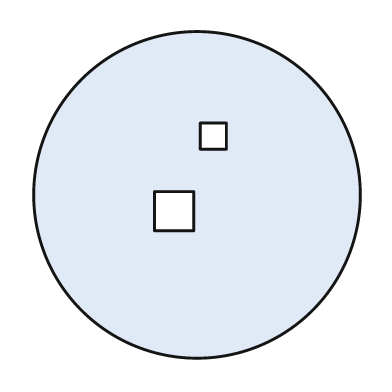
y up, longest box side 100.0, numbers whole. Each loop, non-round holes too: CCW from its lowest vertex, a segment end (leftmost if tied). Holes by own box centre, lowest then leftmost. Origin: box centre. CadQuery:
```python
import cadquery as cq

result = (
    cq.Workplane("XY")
    .moveTo(0.0, 0.0)
    .circle(50.0)
    .moveTo(-13.0, -11.0)
    .lineTo(-1.0, -11.0)
    .lineTo(-1.0, 1.0)
    .lineTo(-13.0, 1.0)
    .close()
    .moveTo(1.0, 14.0)
    .lineTo(9.0, 14.0)
    .lineTo(9.0, 22.0)
    .lineTo(1.0, 22.0)
    .close()
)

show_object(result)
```